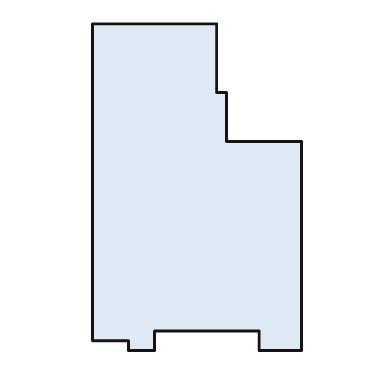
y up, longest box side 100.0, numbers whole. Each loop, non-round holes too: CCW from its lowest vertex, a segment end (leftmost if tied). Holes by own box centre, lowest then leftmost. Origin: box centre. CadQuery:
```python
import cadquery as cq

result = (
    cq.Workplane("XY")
    .moveTo(-21.0, -50.0)
    .lineTo(-13.0, -50.0)
    .lineTo(-13.0, -44.0)
    .lineTo(19.0, -44.0)
    .lineTo(19.0, -50.0)
    .lineTo(32.0, -50.0)
    .lineTo(32.0, 14.0)
    .lineTo(9.0, 14.0)
    .lineTo(9.0, 29.0)
    .lineTo(6.0, 29.0)
    .lineTo(6.0, 50.0)
    .lineTo(-32.0, 50.0)
    .lineTo(-32.0, -47.0)
    .lineTo(-21.0, -47.0)
    .close()
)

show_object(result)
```